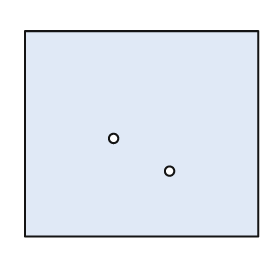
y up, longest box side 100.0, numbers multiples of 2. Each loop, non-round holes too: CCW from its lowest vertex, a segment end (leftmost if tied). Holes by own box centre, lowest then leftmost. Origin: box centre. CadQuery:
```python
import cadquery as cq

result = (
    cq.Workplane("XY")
    .moveTo(-50.0, -44.0)
    .lineTo(50.0, -44.0)
    .lineTo(50.0, 44.0)
    .lineTo(-50.0, 44.0)
    .close()
    .moveTo(12.0, -16.0)
    .circle(2.0)
    .moveTo(-12.0, -2.0)
    .circle(2.0)
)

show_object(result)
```